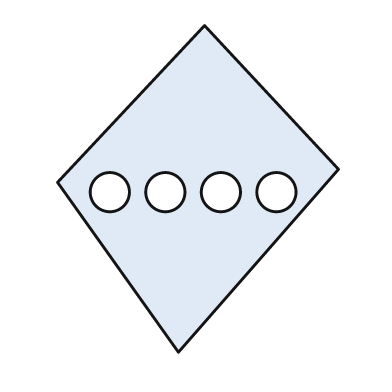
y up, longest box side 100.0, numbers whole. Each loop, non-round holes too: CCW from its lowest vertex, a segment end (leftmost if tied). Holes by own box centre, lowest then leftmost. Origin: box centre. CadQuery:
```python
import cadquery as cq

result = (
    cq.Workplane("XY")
    .moveTo(-6.0, -50.0)
    .lineTo(43.0, 6.0)
    .lineTo(2.0, 50.0)
    .lineTo(-43.0, 2.0)
    .close()
    .moveTo(-27.0, -1.0)
    .circle(6.0)
    .moveTo(-10.0, -1.0)
    .circle(6.0)
    .moveTo(7.0, -1.0)
    .circle(6.0)
    .moveTo(24.0, -1.0)
    .circle(6.0)
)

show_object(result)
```